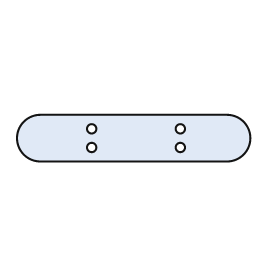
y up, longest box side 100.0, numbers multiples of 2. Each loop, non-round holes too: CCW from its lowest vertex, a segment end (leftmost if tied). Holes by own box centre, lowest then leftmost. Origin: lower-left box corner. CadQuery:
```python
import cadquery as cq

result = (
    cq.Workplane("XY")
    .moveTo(10.0, 0.0)
    .lineTo(90.0, 0.0)
    .threePointArc((100.0, 10.0), (90.0, 20.0))
    .lineTo(10.0, 20.0)
    .threePointArc((0.0, 10.0), (10.0, 0.0))
    .close()
    .moveTo(32.0, 6.0)
    .circle(2.0)
    .moveTo(70.0, 6.0)
    .circle(2.0)
    .moveTo(32.0, 14.0)
    .circle(2.0)
    .moveTo(70.0, 14.0)
    .circle(2.0)
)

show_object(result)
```